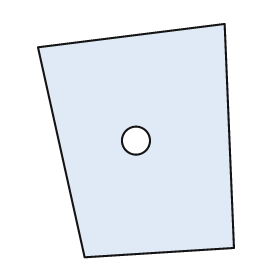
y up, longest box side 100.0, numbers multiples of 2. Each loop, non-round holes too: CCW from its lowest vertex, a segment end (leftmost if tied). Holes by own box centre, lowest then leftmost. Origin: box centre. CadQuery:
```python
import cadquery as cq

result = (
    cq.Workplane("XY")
    .moveTo(-22.0, -50.0)
    .lineTo(42.0, -46.0)
    .lineTo(38.0, 50.0)
    .lineTo(-42.0, 40.0)
    .close()
    .moveTo(0.0, 0.0)
    .circle(6.0)
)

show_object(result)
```